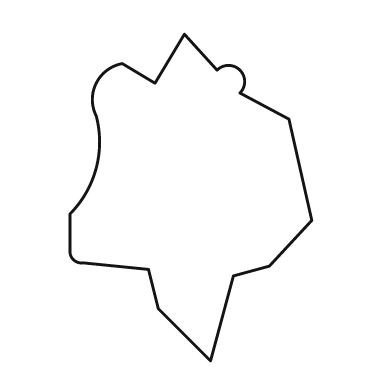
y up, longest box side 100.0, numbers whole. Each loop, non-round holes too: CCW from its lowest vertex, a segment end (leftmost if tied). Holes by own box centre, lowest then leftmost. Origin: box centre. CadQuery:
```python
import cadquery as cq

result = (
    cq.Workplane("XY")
    .moveTo(6.0, -50.0)
    .lineTo(13.0, -24.0)
    .lineTo(24.0, -21.0)
    .lineTo(37.0, -7.0)
    .lineTo(30.0, 24.0)
    .lineTo(15.0, 32.0)
    .threePointArc((15.0, 39.0), (8.0, 39.0))
    .lineTo(-2.0, 50.0)
    .lineTo(-11.0, 35.0)
    .lineTo(-21.0, 41.0)
    .threePointArc((-29.0, 35.0), (-29.0, 25.0))
    .threePointArc((-29.0, 9.0), (-37.0, -5.0))
    .lineTo(-37.0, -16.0)
    .threePointArc((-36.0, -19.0), (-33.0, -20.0))
    .lineTo(-13.0, -22.0)
    .lineTo(-10.0, -34.0)
    .close()
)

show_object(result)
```